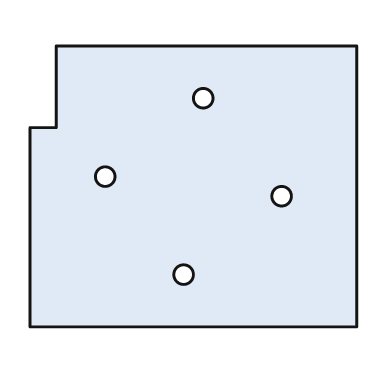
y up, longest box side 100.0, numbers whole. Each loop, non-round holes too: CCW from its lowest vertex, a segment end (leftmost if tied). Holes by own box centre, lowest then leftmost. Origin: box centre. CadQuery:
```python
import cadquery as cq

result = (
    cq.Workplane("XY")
    .moveTo(-50.0, -43.0)
    .lineTo(50.0, -43.0)
    .lineTo(50.0, 43.0)
    .lineTo(-42.0, 43.0)
    .lineTo(-42.0, 18.0)
    .lineTo(-50.0, 18.0)
    .close()
    .moveTo(-3.0, -27.0)
    .circle(3.0)
    .moveTo(27.0, -3.0)
    .circle(3.0)
    .moveTo(-27.0, 3.0)
    .circle(3.0)
    .moveTo(3.0, 27.0)
    .circle(3.0)
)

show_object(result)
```